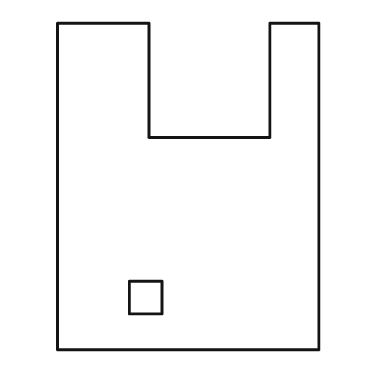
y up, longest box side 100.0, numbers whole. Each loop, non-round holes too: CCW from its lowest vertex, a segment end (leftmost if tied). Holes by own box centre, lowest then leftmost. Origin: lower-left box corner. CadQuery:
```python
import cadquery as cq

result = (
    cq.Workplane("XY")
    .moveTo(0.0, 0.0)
    .lineTo(80.0, 0.0)
    .lineTo(80.0, 100.0)
    .lineTo(65.0, 100.0)
    .lineTo(65.0, 65.0)
    .lineTo(28.0, 65.0)
    .lineTo(28.0, 100.0)
    .lineTo(0.0, 100.0)
    .close()
    .moveTo(22.0, 11.0)
    .lineTo(32.0, 11.0)
    .lineTo(32.0, 21.0)
    .lineTo(22.0, 21.0)
    .close()
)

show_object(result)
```